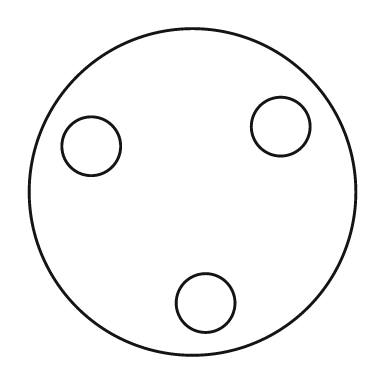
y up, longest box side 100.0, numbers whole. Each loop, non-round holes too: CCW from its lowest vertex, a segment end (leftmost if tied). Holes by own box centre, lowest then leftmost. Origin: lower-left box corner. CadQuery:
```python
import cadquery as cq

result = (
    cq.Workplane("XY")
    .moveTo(50.0, 50.0)
    .circle(50.0)
    .moveTo(54.0, 16.0)
    .circle(9.0)
    .moveTo(19.0, 64.0)
    .circle(9.0)
    .moveTo(77.0, 70.0)
    .circle(9.0)
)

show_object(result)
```